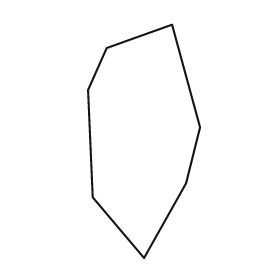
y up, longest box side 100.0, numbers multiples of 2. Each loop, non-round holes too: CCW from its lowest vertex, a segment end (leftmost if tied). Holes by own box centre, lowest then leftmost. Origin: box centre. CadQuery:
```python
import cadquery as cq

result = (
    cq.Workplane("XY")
    .moveTo(0.0, -50.0)
    .lineTo(18.0, -18.0)
    .lineTo(24.0, 6.0)
    .lineTo(12.0, 50.0)
    .lineTo(-16.0, 40.0)
    .lineTo(-24.0, 22.0)
    .lineTo(-22.0, -24.0)
    .close()
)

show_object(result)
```